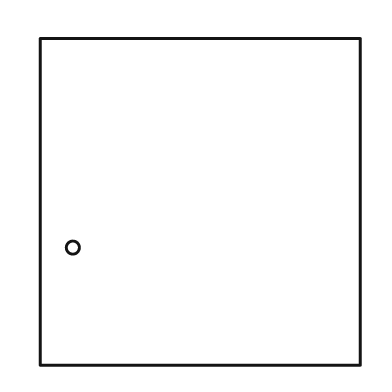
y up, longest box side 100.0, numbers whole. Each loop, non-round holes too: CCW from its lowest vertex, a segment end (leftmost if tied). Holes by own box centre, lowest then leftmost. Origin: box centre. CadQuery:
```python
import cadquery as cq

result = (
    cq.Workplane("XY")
    .moveTo(-49.0, -50.0)
    .lineTo(49.0, -50.0)
    .lineTo(49.0, 50.0)
    .lineTo(-49.0, 50.0)
    .close()
    .moveTo(-39.0, -14.0)
    .circle(2.0)
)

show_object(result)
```